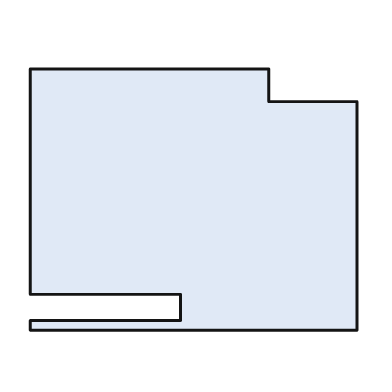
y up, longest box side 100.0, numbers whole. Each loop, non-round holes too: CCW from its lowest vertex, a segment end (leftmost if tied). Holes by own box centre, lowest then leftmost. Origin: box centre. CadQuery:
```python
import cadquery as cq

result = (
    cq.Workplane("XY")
    .moveTo(-50.0, -40.0)
    .lineTo(50.0, -40.0)
    .lineTo(50.0, 30.0)
    .lineTo(23.0, 30.0)
    .lineTo(23.0, 40.0)
    .lineTo(-50.0, 40.0)
    .lineTo(-50.0, -29.0)
    .lineTo(-4.0, -29.0)
    .lineTo(-4.0, -37.0)
    .lineTo(-50.0, -37.0)
    .close()
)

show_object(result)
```